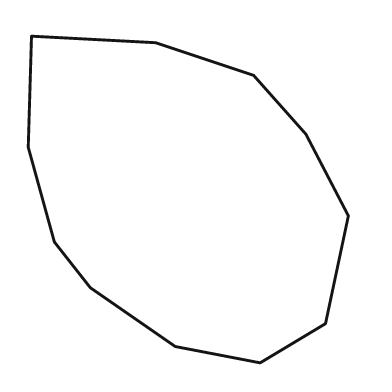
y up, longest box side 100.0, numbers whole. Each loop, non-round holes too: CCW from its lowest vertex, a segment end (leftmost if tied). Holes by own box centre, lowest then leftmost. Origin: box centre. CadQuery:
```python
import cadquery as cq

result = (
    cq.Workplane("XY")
    .moveTo(22.0, -50.0)
    .lineTo(42.0, -38.0)
    .lineTo(49.0, -5.0)
    .lineTo(36.0, 20.0)
    .lineTo(20.0, 38.0)
    .lineTo(-10.0, 48.0)
    .lineTo(-48.0, 50.0)
    .lineTo(-49.0, 16.0)
    .lineTo(-41.0, -13.0)
    .lineTo(-30.0, -27.0)
    .lineTo(-4.0, -45.0)
    .close()
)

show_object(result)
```